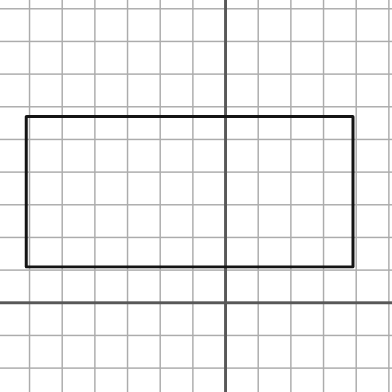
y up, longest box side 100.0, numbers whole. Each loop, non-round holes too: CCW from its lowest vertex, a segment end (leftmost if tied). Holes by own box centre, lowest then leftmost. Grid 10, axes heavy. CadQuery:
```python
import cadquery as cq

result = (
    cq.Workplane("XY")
    .moveTo(-61.0, 11.0)
    .lineTo(39.0, 11.0)
    .lineTo(39.0, 57.0)
    .lineTo(-61.0, 57.0)
    .close()
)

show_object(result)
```